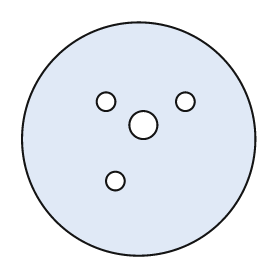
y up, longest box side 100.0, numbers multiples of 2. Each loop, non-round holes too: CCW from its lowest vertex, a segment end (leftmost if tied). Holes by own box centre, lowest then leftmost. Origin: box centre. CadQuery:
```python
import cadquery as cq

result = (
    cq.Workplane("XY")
    .moveTo(0.0, 0.0)
    .circle(50.0)
    .moveTo(-10.0, -18.0)
    .circle(4.0)
    .moveTo(2.0, 6.0)
    .circle(6.0)
    .moveTo(-14.0, 16.0)
    .circle(4.0)
    .moveTo(20.0, 16.0)
    .circle(4.0)
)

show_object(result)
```